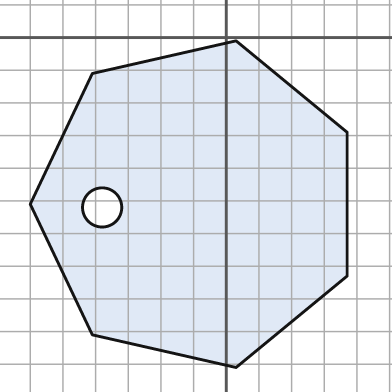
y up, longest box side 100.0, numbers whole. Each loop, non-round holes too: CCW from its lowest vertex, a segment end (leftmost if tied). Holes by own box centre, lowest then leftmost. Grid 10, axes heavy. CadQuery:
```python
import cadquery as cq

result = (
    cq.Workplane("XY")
    .moveTo(3.0, -101.0)
    .lineTo(37.0, -73.0)
    .lineTo(37.0, -29.0)
    .lineTo(3.0, -1.0)
    .lineTo(-41.0, -11.0)
    .lineTo(-60.0, -51.0)
    .lineTo(-41.0, -91.0)
    .close()
    .moveTo(-38.0, -52.0)
    .circle(6.0)
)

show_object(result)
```